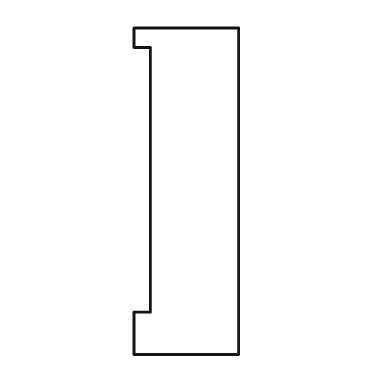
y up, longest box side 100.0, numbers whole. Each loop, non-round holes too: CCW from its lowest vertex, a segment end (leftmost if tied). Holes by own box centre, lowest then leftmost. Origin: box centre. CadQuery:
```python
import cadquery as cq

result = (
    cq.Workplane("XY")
    .moveTo(-16.0, -50.0)
    .lineTo(16.0, -50.0)
    .lineTo(16.0, 50.0)
    .lineTo(-16.0, 50.0)
    .lineTo(-16.0, 44.0)
    .lineTo(-11.0, 44.0)
    .lineTo(-11.0, -37.0)
    .lineTo(-16.0, -37.0)
    .close()
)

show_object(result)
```